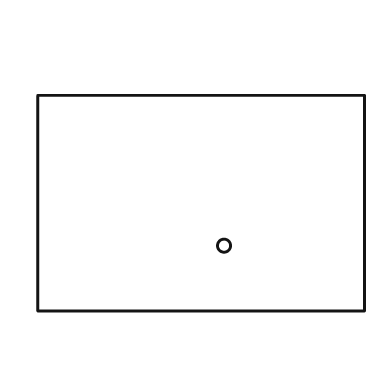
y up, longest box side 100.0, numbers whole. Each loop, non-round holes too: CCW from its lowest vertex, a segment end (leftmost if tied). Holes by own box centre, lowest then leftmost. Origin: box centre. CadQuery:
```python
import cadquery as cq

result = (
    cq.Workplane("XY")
    .moveTo(-50.0, -33.0)
    .lineTo(50.0, -33.0)
    .lineTo(50.0, 33.0)
    .lineTo(-50.0, 33.0)
    .close()
    .moveTo(7.0, -13.0)
    .circle(2.0)
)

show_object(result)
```